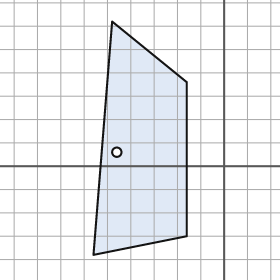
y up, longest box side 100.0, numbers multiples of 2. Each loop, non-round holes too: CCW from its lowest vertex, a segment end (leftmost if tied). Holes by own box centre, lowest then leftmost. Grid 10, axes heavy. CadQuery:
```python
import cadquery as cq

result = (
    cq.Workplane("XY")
    .moveTo(-56.0, -38.0)
    .lineTo(-16.0, -30.0)
    .lineTo(-16.0, 36.0)
    .lineTo(-48.0, 62.0)
    .close()
    .moveTo(-46.0, 6.0)
    .circle(2.0)
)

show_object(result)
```